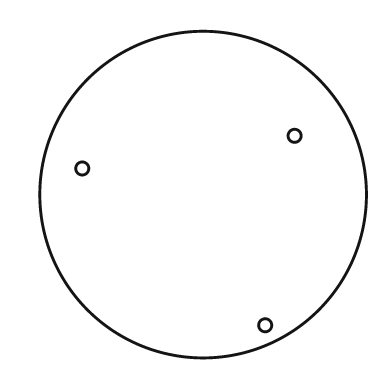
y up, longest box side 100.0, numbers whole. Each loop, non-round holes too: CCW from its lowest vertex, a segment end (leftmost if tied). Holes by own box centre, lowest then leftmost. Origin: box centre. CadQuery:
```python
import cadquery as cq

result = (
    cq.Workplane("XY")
    .moveTo(0.0, 0.0)
    .circle(50.0)
    .moveTo(19.0, -40.0)
    .circle(2.0)
    .moveTo(-37.0, 8.0)
    .circle(2.0)
    .moveTo(28.0, 18.0)
    .circle(2.0)
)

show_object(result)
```